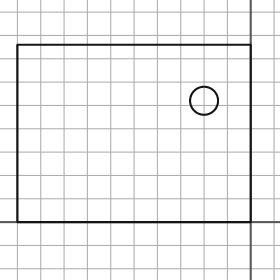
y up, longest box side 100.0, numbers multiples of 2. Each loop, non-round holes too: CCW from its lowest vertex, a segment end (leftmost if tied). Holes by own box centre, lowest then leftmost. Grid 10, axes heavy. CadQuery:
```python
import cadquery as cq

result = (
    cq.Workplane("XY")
    .moveTo(-100.0, 0.0)
    .lineTo(0.0, 0.0)
    .lineTo(0.0, 76.0)
    .lineTo(-100.0, 76.0)
    .close()
    .moveTo(-20.0, 52.0)
    .circle(6.0)
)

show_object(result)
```